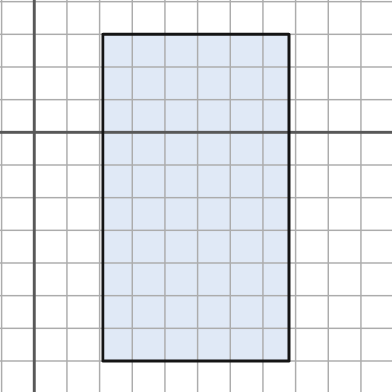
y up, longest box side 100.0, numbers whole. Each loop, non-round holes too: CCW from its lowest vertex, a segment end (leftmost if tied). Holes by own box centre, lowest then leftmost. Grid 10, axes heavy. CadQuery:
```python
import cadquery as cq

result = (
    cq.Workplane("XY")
    .moveTo(21.0, -70.0)
    .lineTo(78.0, -70.0)
    .lineTo(78.0, 30.0)
    .lineTo(21.0, 30.0)
    .close()
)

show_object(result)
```